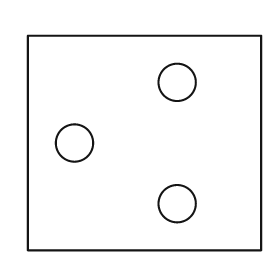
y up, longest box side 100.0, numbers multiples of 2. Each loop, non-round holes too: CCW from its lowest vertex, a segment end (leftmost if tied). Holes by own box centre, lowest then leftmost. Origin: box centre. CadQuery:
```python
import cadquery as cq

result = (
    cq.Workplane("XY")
    .moveTo(-50.0, -46.0)
    .lineTo(50.0, -46.0)
    .lineTo(50.0, 46.0)
    .lineTo(-50.0, 46.0)
    .close()
    .moveTo(14.0, -26.0)
    .circle(8.0)
    .moveTo(-30.0, 0.0)
    .circle(8.0)
    .moveTo(14.0, 26.0)
    .circle(8.0)
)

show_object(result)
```